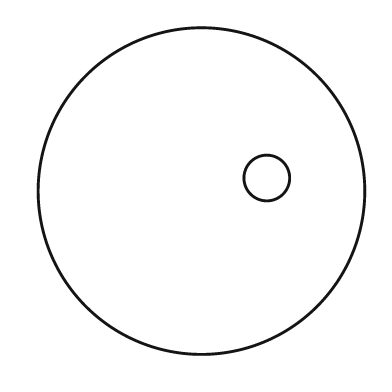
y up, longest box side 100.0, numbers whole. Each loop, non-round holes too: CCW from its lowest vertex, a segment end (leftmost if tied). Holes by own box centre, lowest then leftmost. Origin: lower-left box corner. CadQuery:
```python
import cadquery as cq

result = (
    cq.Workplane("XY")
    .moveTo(50.0, 50.0)
    .circle(50.0)
    .moveTo(70.0, 54.0)
    .circle(7.0)
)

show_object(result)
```